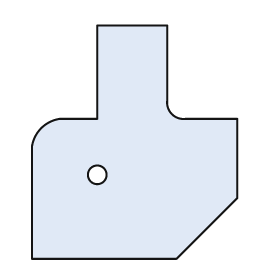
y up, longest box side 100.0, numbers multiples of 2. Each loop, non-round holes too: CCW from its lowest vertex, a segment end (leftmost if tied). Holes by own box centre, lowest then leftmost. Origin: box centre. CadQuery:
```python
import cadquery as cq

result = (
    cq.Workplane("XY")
    .moveTo(-44.0, -50.0)
    .lineTo(18.0, -50.0)
    .lineTo(44.0, -24.0)
    .lineTo(44.0, 10.0)
    .lineTo(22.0, 10.0)
    .threePointArc((16.0, 12.0), (14.0, 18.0))
    .lineTo(14.0, 50.0)
    .lineTo(-16.0, 50.0)
    .lineTo(-16.0, 10.0)
    .lineTo(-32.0, 10.0)
    .threePointArc((-40.0, 6.0), (-44.0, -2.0))
    .close()
    .moveTo(-16.0, -14.0)
    .circle(4.0)
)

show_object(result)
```